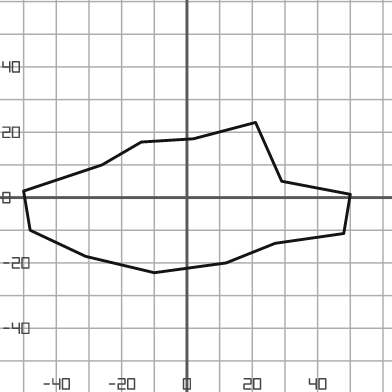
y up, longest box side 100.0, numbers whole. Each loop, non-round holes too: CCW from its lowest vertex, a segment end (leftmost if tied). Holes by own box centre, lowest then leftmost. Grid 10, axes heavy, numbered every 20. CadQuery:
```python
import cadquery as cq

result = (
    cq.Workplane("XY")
    .moveTo(-10.0, -23.0)
    .lineTo(12.0, -20.0)
    .lineTo(27.0, -14.0)
    .lineTo(48.0, -11.0)
    .lineTo(50.0, 1.0)
    .lineTo(29.0, 5.0)
    .lineTo(21.0, 23.0)
    .lineTo(2.0, 18.0)
    .lineTo(-14.0, 17.0)
    .lineTo(-26.0, 10.0)
    .lineTo(-50.0, 2.0)
    .lineTo(-48.0, -10.0)
    .lineTo(-31.0, -18.0)
    .close()
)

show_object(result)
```